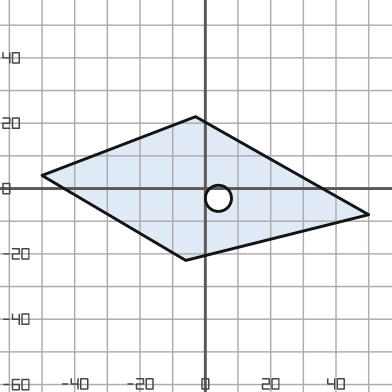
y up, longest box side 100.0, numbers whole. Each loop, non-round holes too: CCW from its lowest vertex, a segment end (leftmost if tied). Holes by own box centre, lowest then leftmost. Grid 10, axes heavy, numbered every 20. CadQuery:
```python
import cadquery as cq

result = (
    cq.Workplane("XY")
    .moveTo(-6.0, -22.0)
    .lineTo(50.0, -8.0)
    .lineTo(-3.0, 22.0)
    .lineTo(-50.0, 4.0)
    .close()
    .moveTo(4.0, -3.0)
    .circle(4.0)
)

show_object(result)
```